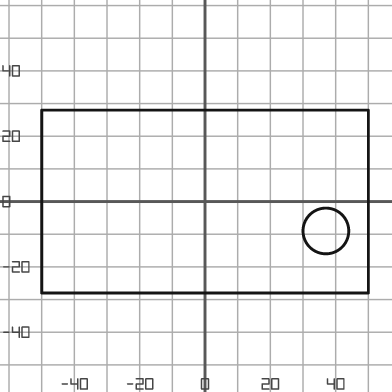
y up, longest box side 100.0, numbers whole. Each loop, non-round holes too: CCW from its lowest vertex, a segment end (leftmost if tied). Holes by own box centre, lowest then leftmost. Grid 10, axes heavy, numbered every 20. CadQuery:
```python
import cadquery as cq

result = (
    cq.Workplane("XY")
    .moveTo(-50.0, -28.0)
    .lineTo(50.0, -28.0)
    .lineTo(50.0, 28.0)
    .lineTo(-50.0, 28.0)
    .close()
    .moveTo(37.0, -9.0)
    .circle(7.0)
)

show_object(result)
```